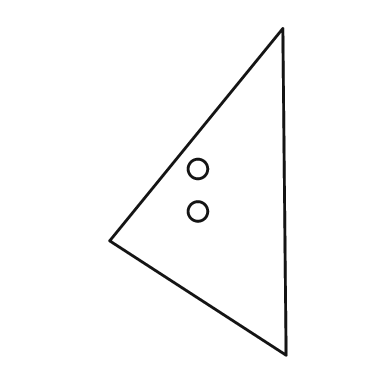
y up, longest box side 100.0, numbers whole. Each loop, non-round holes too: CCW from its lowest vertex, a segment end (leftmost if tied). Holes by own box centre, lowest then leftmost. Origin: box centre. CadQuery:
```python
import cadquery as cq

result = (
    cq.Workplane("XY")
    .moveTo(27.0, -50.0)
    .lineTo(26.0, 50.0)
    .lineTo(-27.0, -15.0)
    .close()
    .moveTo(0.0, -6.0)
    .circle(3.0)
    .moveTo(0.0, 7.0)
    .circle(3.0)
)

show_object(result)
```